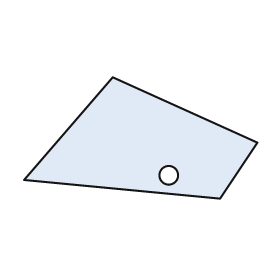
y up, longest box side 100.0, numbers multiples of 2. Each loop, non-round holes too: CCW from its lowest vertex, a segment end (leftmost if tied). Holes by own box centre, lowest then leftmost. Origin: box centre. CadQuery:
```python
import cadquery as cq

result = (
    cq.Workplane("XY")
    .moveTo(34.0, -26.0)
    .lineTo(50.0, -2.0)
    .lineTo(-12.0, 26.0)
    .lineTo(-50.0, -18.0)
    .close()
    .moveTo(12.0, -16.0)
    .circle(4.0)
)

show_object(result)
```